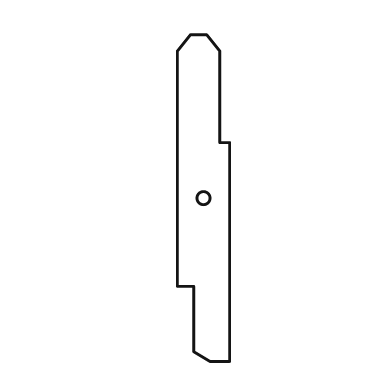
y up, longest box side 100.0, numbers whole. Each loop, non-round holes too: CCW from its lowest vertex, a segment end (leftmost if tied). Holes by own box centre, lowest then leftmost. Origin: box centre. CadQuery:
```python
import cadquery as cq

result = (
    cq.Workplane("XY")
    .moveTo(2.0, -50.0)
    .lineTo(8.0, -50.0)
    .lineTo(8.0, 17.0)
    .lineTo(5.0, 17.0)
    .lineTo(5.0, 45.0)
    .lineTo(1.0, 50.0)
    .lineTo(-4.0, 50.0)
    .lineTo(-8.0, 45.0)
    .lineTo(-8.0, -27.0)
    .lineTo(-3.0, -27.0)
    .lineTo(-3.0, -47.0)
    .close()
    .moveTo(0.0, 0.0)
    .circle(2.0)
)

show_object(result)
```